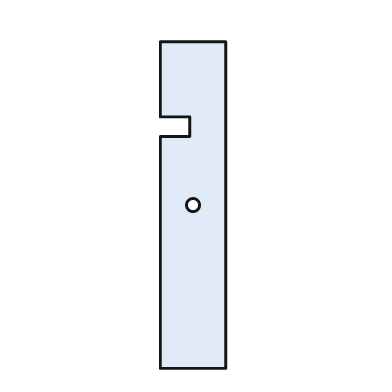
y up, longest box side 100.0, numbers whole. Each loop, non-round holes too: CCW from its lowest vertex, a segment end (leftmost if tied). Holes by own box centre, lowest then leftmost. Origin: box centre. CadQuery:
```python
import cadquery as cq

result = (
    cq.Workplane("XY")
    .moveTo(-10.0, -50.0)
    .lineTo(10.0, -50.0)
    .lineTo(10.0, 50.0)
    .lineTo(-10.0, 50.0)
    .lineTo(-10.0, 27.0)
    .lineTo(-1.0, 27.0)
    .lineTo(-1.0, 21.0)
    .lineTo(-10.0, 21.0)
    .close()
    .moveTo(0.0, 0.0)
    .circle(2.0)
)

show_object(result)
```